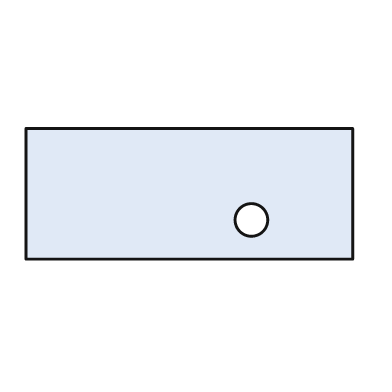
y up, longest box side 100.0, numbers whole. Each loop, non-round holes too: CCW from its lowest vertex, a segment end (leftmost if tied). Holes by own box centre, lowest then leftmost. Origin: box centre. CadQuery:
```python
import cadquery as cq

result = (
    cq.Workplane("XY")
    .moveTo(-50.0, -20.0)
    .lineTo(50.0, -20.0)
    .lineTo(50.0, 20.0)
    .lineTo(-50.0, 20.0)
    .close()
    .moveTo(19.0, -8.0)
    .circle(5.0)
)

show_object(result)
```